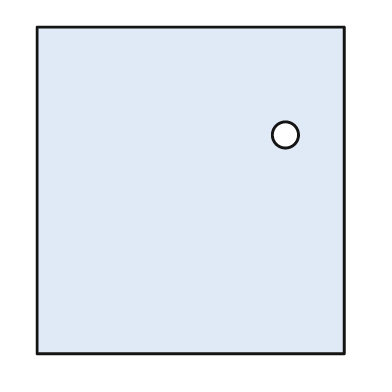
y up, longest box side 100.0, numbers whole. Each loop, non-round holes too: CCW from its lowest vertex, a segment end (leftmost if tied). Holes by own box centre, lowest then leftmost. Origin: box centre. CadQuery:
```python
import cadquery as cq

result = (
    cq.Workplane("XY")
    .moveTo(-47.0, -50.0)
    .lineTo(47.0, -50.0)
    .lineTo(47.0, 50.0)
    .lineTo(-47.0, 50.0)
    .close()
    .moveTo(29.0, 17.0)
    .circle(4.0)
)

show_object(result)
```